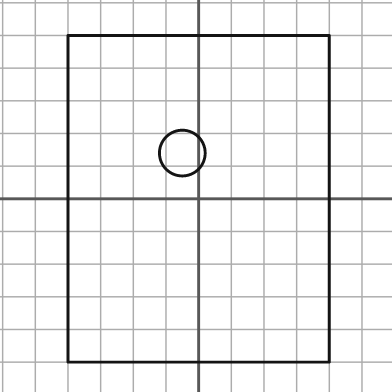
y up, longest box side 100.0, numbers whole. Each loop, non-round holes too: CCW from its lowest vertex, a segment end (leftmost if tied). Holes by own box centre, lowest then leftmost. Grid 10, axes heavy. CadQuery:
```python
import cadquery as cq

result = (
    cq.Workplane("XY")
    .moveTo(-40.0, -50.0)
    .lineTo(40.0, -50.0)
    .lineTo(40.0, 50.0)
    .lineTo(-40.0, 50.0)
    .close()
    .moveTo(-5.0, 14.0)
    .circle(7.0)
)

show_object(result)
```